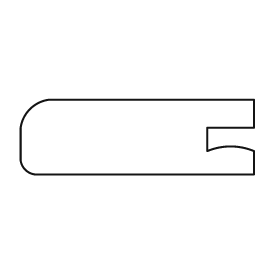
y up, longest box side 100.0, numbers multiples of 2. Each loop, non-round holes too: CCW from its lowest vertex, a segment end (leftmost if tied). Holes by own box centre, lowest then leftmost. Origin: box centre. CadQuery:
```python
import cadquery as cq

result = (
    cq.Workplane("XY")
    .moveTo(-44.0, -16.0)
    .lineTo(50.0, -16.0)
    .lineTo(50.0, -6.0)
    .threePointArc((40.0, -4.0), (30.0, -6.0))
    .lineTo(30.0, 4.0)
    .lineTo(50.0, 4.0)
    .lineTo(50.0, 16.0)
    .lineTo(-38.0, 16.0)
    .threePointArc((-46.0, 12.0), (-50.0, 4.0))
    .lineTo(-50.0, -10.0)
    .threePointArc((-48.0, -14.0), (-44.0, -16.0))
    .close()
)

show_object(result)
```